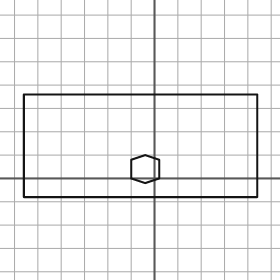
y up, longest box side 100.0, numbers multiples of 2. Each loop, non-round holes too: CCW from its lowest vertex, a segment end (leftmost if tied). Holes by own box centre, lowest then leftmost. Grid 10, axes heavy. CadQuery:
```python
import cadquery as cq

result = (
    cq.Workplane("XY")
    .moveTo(-56.0, -8.0)
    .lineTo(44.0, -8.0)
    .lineTo(44.0, 36.0)
    .lineTo(-56.0, 36.0)
    .close()
    .moveTo(-4.0, -2.0)
    .lineTo(2.0, 0.0)
    .lineTo(2.0, 8.0)
    .lineTo(-4.0, 10.0)
    .lineTo(-10.0, 8.0)
    .lineTo(-10.0, 0.0)
    .close()
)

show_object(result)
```